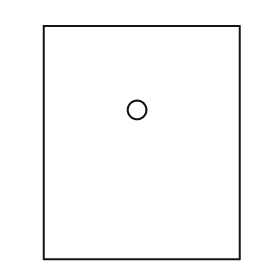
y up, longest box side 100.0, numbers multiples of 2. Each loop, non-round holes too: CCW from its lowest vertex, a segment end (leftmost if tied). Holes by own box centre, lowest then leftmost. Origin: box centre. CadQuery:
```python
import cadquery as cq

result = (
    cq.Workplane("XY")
    .moveTo(-42.0, -50.0)
    .lineTo(42.0, -50.0)
    .lineTo(42.0, 50.0)
    .lineTo(-42.0, 50.0)
    .close()
    .moveTo(-2.0, 14.0)
    .circle(4.0)
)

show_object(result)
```